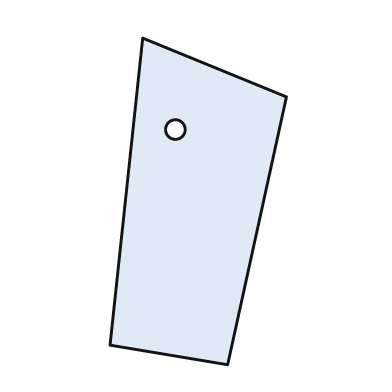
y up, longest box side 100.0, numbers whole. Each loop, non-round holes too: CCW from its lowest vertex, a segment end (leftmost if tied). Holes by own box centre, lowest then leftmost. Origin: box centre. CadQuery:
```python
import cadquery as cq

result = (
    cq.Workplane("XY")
    .moveTo(9.0, -50.0)
    .lineTo(27.0, 32.0)
    .lineTo(-17.0, 50.0)
    .lineTo(-27.0, -44.0)
    .close()
    .moveTo(-7.0, 22.0)
    .circle(3.0)
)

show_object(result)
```